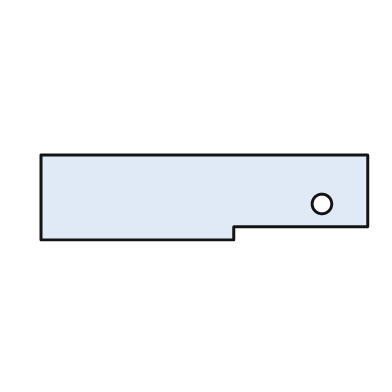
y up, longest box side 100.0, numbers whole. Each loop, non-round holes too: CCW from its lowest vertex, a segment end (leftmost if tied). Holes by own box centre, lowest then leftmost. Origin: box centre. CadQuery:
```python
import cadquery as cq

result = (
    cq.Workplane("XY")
    .moveTo(-50.0, -13.0)
    .lineTo(9.0, -13.0)
    .lineTo(9.0, -9.0)
    .lineTo(50.0, -9.0)
    .lineTo(50.0, 13.0)
    .lineTo(-50.0, 13.0)
    .close()
    .moveTo(36.0, -2.0)
    .circle(3.0)
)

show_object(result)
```